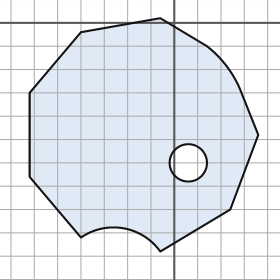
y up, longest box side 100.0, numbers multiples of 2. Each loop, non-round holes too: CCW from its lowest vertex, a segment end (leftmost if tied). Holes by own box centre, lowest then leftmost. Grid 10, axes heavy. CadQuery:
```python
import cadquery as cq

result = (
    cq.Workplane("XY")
    .moveTo(-6.0, -98.0)
    .lineTo(24.0, -80.0)
    .lineTo(36.0, -48.0)
    .lineTo(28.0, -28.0)
    .threePointArc((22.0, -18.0), (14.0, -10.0))
    .lineTo(-6.0, 2.0)
    .lineTo(-40.0, -4.0)
    .lineTo(-62.0, -30.0)
    .lineTo(-62.0, -66.0)
    .lineTo(-40.0, -92.0)
    .threePointArc((-22.0, -88.0), (-6.0, -98.0))
    .close()
    .moveTo(6.0, -60.0)
    .circle(8.0)
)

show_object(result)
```